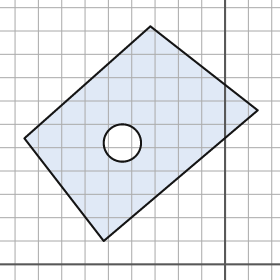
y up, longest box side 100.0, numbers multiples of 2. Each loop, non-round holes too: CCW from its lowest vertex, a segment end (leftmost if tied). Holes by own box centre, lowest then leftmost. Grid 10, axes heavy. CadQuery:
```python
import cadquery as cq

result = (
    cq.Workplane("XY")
    .moveTo(-52.0, 10.0)
    .lineTo(14.0, 66.0)
    .lineTo(-32.0, 102.0)
    .lineTo(-86.0, 54.0)
    .close()
    .moveTo(-44.0, 52.0)
    .circle(8.0)
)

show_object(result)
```